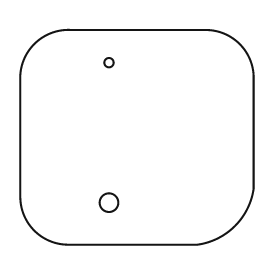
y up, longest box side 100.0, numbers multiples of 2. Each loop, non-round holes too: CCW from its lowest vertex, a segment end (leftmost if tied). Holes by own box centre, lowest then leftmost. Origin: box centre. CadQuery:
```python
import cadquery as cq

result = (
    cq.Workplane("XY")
    .moveTo(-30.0, -46.0)
    .lineTo(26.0, -46.0)
    .threePointArc((42.0, -38.0), (50.0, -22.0))
    .lineTo(50.0, 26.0)
    .threePointArc((44.0, 40.0), (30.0, 46.0))
    .lineTo(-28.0, 46.0)
    .threePointArc((-44.0, 40.0), (-50.0, 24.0))
    .lineTo(-50.0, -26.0)
    .threePointArc((-44.0, -40.0), (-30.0, -46.0))
    .close()
    .moveTo(-12.0, -28.0)
    .circle(4.0)
    .moveTo(-12.0, 32.0)
    .circle(2.0)
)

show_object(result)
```